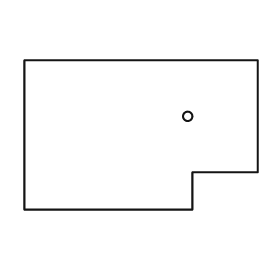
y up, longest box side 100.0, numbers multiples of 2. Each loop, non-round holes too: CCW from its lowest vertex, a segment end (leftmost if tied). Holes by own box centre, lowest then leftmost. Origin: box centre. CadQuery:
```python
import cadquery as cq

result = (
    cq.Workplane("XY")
    .moveTo(-50.0, -32.0)
    .lineTo(22.0, -32.0)
    .lineTo(22.0, -16.0)
    .lineTo(50.0, -16.0)
    .lineTo(50.0, 32.0)
    .lineTo(-50.0, 32.0)
    .close()
    .moveTo(20.0, 8.0)
    .circle(2.0)
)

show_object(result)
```